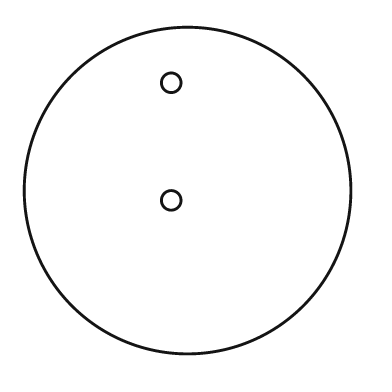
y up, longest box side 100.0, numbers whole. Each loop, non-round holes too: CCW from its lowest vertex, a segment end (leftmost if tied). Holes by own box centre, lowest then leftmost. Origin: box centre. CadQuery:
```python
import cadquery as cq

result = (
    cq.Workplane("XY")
    .moveTo(0.0, 0.0)
    .circle(50.0)
    .moveTo(-5.0, -3.0)
    .circle(3.0)
    .moveTo(-5.0, 33.0)
    .circle(3.0)
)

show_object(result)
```